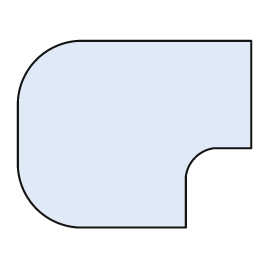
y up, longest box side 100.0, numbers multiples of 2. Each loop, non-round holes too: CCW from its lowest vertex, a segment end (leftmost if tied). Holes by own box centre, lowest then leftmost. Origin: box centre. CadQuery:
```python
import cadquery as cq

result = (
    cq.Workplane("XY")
    .moveTo(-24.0, -40.0)
    .lineTo(22.0, -40.0)
    .lineTo(22.0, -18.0)
    .threePointArc((26.0, -10.0), (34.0, -6.0))
    .lineTo(50.0, -6.0)
    .lineTo(50.0, 40.0)
    .lineTo(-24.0, 40.0)
    .threePointArc((-42.0, 32.0), (-50.0, 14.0))
    .lineTo(-50.0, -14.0)
    .threePointArc((-42.0, -32.0), (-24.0, -40.0))
    .close()
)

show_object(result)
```